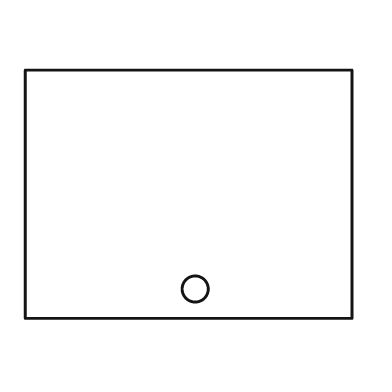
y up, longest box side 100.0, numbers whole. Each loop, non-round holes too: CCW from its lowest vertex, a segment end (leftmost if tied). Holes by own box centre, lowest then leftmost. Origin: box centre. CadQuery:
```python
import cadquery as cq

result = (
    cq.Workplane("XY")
    .moveTo(-50.0, -38.0)
    .lineTo(50.0, -38.0)
    .lineTo(50.0, 38.0)
    .lineTo(-50.0, 38.0)
    .close()
    .moveTo(2.0, -29.0)
    .circle(4.0)
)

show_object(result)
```